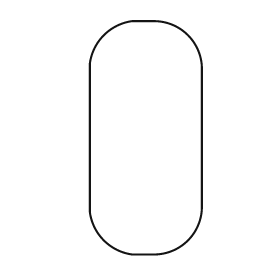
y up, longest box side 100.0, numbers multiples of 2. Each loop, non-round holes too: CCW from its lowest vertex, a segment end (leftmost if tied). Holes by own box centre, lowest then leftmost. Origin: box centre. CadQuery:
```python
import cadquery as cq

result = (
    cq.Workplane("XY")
    .moveTo(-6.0, -50.0)
    .lineTo(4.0, -50.0)
    .threePointArc((18.0, -44.0), (24.0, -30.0))
    .lineTo(24.0, 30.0)
    .threePointArc((18.0, 44.0), (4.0, 50.0))
    .lineTo(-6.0, 50.0)
    .threePointArc((-18.0, 44.0), (-24.0, 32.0))
    .lineTo(-24.0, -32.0)
    .threePointArc((-18.0, -44.0), (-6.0, -50.0))
    .close()
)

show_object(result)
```